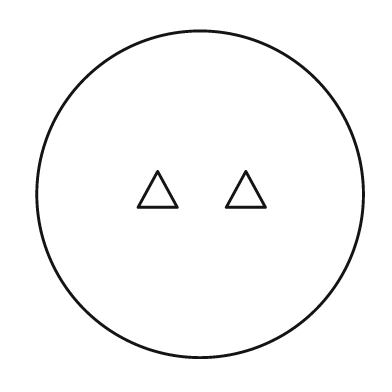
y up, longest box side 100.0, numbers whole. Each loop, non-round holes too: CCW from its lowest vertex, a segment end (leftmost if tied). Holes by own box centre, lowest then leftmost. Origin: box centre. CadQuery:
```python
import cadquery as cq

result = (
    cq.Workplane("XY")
    .moveTo(0.0, 0.0)
    .circle(50.0)
    .moveTo(-19.0, -4.0)
    .lineTo(-7.0, -4.0)
    .lineTo(-13.0, 7.0)
    .close()
    .moveTo(8.0, -4.0)
    .lineTo(20.0, -4.0)
    .lineTo(14.0, 7.0)
    .close()
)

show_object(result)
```